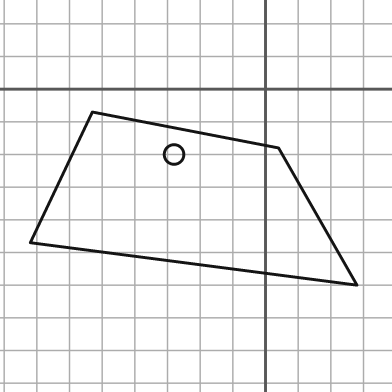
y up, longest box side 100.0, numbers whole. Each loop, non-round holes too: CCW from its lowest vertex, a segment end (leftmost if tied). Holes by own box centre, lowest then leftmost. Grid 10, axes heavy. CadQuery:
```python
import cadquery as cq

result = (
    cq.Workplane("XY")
    .moveTo(28.0, -60.0)
    .lineTo(4.0, -18.0)
    .lineTo(-53.0, -7.0)
    .lineTo(-72.0, -47.0)
    .close()
    .moveTo(-28.0, -20.0)
    .circle(3.0)
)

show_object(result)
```